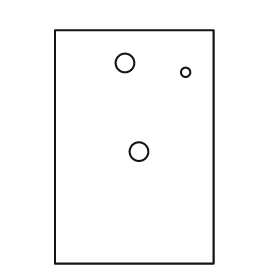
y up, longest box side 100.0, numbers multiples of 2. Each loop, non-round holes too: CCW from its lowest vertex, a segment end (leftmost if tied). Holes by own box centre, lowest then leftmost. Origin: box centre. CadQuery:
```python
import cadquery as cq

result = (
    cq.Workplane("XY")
    .moveTo(-34.0, -50.0)
    .lineTo(34.0, -50.0)
    .lineTo(34.0, 50.0)
    .lineTo(-34.0, 50.0)
    .close()
    .moveTo(2.0, -2.0)
    .circle(4.0)
    .moveTo(22.0, 32.0)
    .circle(2.0)
    .moveTo(-4.0, 36.0)
    .circle(4.0)
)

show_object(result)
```